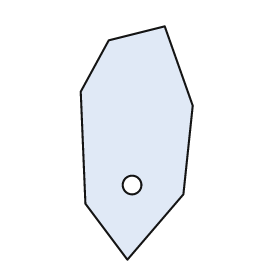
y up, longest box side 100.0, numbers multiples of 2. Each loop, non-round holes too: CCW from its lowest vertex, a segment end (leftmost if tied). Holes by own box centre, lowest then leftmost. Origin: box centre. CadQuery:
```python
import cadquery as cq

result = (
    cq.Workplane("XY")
    .moveTo(-4.0, -50.0)
    .lineTo(20.0, -22.0)
    .lineTo(24.0, 16.0)
    .lineTo(12.0, 50.0)
    .lineTo(-12.0, 44.0)
    .lineTo(-24.0, 22.0)
    .lineTo(-22.0, -26.0)
    .close()
    .moveTo(-2.0, -18.0)
    .circle(4.0)
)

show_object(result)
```